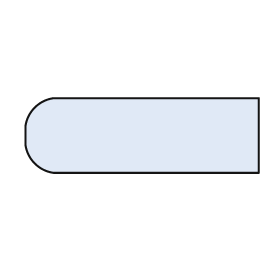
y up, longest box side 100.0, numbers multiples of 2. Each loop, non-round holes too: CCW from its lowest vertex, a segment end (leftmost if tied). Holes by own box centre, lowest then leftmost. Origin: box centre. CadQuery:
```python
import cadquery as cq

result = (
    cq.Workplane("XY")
    .moveTo(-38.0, -16.0)
    .lineTo(50.0, -16.0)
    .lineTo(50.0, 16.0)
    .lineTo(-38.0, 16.0)
    .threePointArc((-46.0, 12.0), (-50.0, 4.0))
    .lineTo(-50.0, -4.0)
    .threePointArc((-46.0, -12.0), (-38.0, -16.0))
    .close()
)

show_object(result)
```